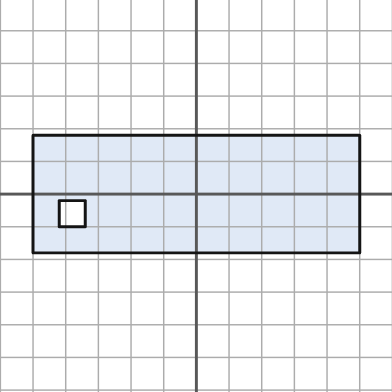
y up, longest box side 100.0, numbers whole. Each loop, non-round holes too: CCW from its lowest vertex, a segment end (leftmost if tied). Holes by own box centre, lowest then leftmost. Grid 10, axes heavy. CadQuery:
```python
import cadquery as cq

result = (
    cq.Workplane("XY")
    .moveTo(-50.0, -18.0)
    .lineTo(50.0, -18.0)
    .lineTo(50.0, 18.0)
    .lineTo(-50.0, 18.0)
    .close()
    .moveTo(-42.0, -10.0)
    .lineTo(-34.0, -10.0)
    .lineTo(-34.0, -2.0)
    .lineTo(-42.0, -2.0)
    .close()
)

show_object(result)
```